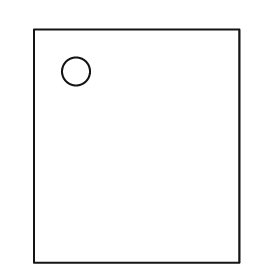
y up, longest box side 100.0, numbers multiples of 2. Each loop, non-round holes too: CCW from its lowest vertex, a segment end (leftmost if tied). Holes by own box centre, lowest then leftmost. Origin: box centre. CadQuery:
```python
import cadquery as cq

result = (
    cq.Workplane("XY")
    .moveTo(-44.0, -50.0)
    .lineTo(44.0, -50.0)
    .lineTo(44.0, 50.0)
    .lineTo(-44.0, 50.0)
    .close()
    .moveTo(-26.0, 32.0)
    .circle(6.0)
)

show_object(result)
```